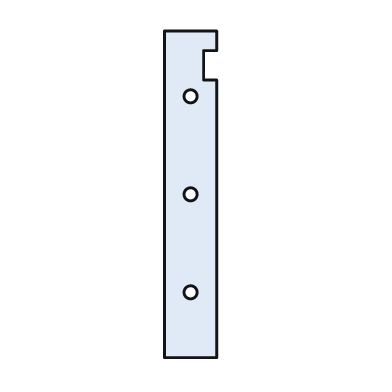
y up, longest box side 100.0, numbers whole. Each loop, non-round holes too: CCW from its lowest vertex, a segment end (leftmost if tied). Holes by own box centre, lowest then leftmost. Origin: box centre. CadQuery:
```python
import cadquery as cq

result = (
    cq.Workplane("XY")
    .moveTo(-8.0, -50.0)
    .lineTo(8.0, -50.0)
    .lineTo(8.0, 35.0)
    .lineTo(4.0, 35.0)
    .lineTo(4.0, 44.0)
    .lineTo(8.0, 44.0)
    .lineTo(8.0, 50.0)
    .lineTo(-8.0, 50.0)
    .close()
    .moveTo(0.0, -30.0)
    .circle(2.0)
    .moveTo(0.0, 0.0)
    .circle(2.0)
    .moveTo(0.0, 30.0)
    .circle(2.0)
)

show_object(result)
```